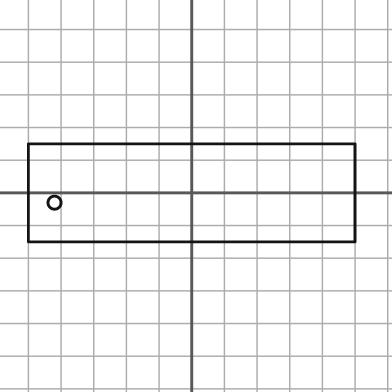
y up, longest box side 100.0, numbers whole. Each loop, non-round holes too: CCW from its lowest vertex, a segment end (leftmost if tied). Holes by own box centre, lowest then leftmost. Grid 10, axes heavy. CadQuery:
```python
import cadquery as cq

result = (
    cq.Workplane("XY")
    .moveTo(-50.0, -15.0)
    .lineTo(50.0, -15.0)
    .lineTo(50.0, 15.0)
    .lineTo(-50.0, 15.0)
    .close()
    .moveTo(-42.0, -3.0)
    .circle(2.0)
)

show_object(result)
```